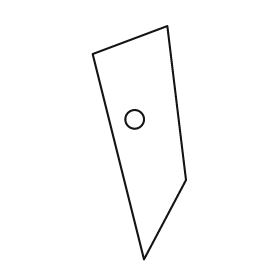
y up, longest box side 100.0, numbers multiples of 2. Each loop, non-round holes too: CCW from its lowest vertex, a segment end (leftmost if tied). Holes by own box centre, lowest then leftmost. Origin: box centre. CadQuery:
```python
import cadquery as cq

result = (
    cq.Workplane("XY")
    .moveTo(2.0, -50.0)
    .lineTo(20.0, -16.0)
    .lineTo(12.0, 50.0)
    .lineTo(-20.0, 38.0)
    .close()
    .moveTo(-2.0, 10.0)
    .circle(4.0)
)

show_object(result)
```